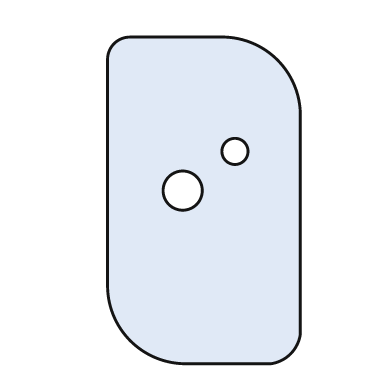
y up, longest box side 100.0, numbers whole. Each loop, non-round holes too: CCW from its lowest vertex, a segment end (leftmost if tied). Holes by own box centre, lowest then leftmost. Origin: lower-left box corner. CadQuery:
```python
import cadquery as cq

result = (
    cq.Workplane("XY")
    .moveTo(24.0, 0.0)
    .lineTo(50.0, 0.0)
    .threePointArc((56.0, 3.0), (59.0, 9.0))
    .lineTo(59.0, 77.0)
    .threePointArc((52.0, 93.0), (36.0, 100.0))
    .lineTo(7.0, 100.0)
    .threePointArc((2.0, 98.0), (0.0, 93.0))
    .lineTo(0.0, 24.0)
    .threePointArc((7.0, 7.0), (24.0, 0.0))
    .close()
    .moveTo(23.0, 53.0)
    .circle(6.0)
    .moveTo(39.0, 65.0)
    .circle(4.0)
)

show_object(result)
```